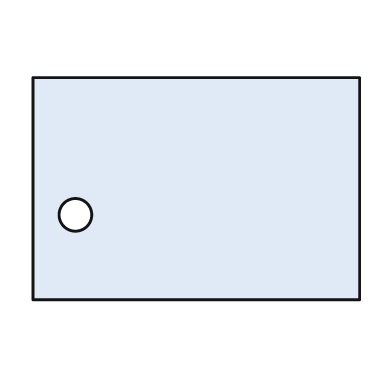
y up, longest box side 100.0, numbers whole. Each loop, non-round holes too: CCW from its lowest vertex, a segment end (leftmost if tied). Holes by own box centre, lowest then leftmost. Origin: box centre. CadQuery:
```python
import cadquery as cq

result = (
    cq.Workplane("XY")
    .moveTo(-50.0, -34.0)
    .lineTo(50.0, -34.0)
    .lineTo(50.0, 34.0)
    .lineTo(-50.0, 34.0)
    .close()
    .moveTo(-37.0, -8.0)
    .circle(5.0)
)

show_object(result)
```